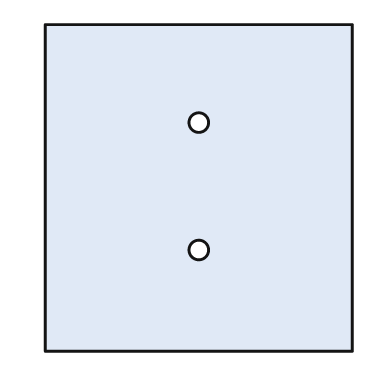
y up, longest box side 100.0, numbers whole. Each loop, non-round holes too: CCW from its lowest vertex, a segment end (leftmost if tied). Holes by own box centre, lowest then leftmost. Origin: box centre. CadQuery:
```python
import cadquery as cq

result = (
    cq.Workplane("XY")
    .moveTo(-47.0, -50.0)
    .lineTo(47.0, -50.0)
    .lineTo(47.0, 50.0)
    .lineTo(-47.0, 50.0)
    .close()
    .moveTo(0.0, -19.0)
    .circle(3.0)
    .moveTo(0.0, 20.0)
    .circle(3.0)
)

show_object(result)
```